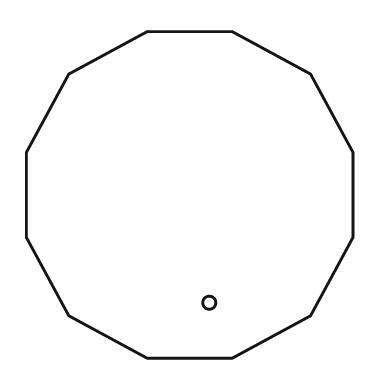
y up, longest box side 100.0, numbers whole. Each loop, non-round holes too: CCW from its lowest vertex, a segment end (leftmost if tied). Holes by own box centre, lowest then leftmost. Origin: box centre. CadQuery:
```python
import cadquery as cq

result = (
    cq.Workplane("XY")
    .moveTo(-13.0, -50.0)
    .lineTo(13.0, -50.0)
    .lineTo(37.0, -37.0)
    .lineTo(50.0, -13.0)
    .lineTo(50.0, 13.0)
    .lineTo(37.0, 37.0)
    .lineTo(13.0, 50.0)
    .lineTo(-13.0, 50.0)
    .lineTo(-37.0, 37.0)
    .lineTo(-50.0, 13.0)
    .lineTo(-50.0, -13.0)
    .lineTo(-37.0, -37.0)
    .close()
    .moveTo(6.0, -33.0)
    .circle(2.0)
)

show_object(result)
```